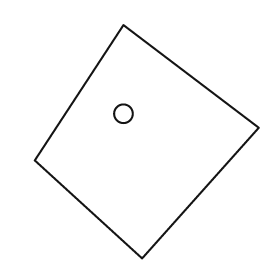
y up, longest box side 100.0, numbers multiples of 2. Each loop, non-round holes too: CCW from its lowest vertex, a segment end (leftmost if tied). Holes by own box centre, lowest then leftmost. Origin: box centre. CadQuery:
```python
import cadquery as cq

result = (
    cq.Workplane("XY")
    .moveTo(-2.0, -50.0)
    .lineTo(48.0, 6.0)
    .lineTo(-10.0, 50.0)
    .lineTo(-48.0, -8.0)
    .close()
    .moveTo(-10.0, 12.0)
    .circle(4.0)
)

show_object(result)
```